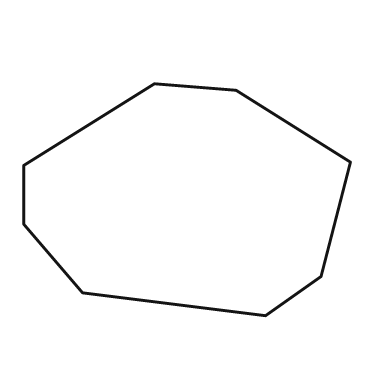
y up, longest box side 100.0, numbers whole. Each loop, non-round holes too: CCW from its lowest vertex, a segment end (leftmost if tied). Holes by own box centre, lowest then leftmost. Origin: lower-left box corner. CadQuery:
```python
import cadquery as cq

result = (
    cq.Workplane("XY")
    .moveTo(74.0, 0.0)
    .lineTo(91.0, 12.0)
    .lineTo(100.0, 47.0)
    .lineTo(65.0, 69.0)
    .lineTo(40.0, 71.0)
    .lineTo(0.0, 46.0)
    .lineTo(0.0, 28.0)
    .lineTo(18.0, 7.0)
    .close()
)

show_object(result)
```